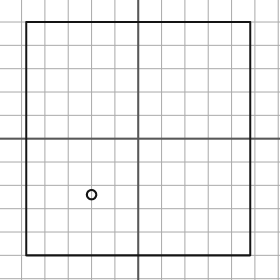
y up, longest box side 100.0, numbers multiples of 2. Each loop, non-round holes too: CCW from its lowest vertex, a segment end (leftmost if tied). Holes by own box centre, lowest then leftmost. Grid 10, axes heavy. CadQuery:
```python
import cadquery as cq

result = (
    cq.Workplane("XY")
    .moveTo(-48.0, -50.0)
    .lineTo(48.0, -50.0)
    .lineTo(48.0, 50.0)
    .lineTo(-48.0, 50.0)
    .close()
    .moveTo(-20.0, -24.0)
    .circle(2.0)
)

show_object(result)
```